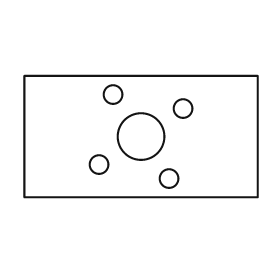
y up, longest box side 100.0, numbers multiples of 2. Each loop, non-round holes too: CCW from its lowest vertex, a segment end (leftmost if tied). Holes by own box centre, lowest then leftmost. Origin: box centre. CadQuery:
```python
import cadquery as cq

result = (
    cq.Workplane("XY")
    .moveTo(-50.0, -26.0)
    .lineTo(50.0, -26.0)
    .lineTo(50.0, 26.0)
    .lineTo(-50.0, 26.0)
    .close()
    .moveTo(12.0, -18.0)
    .circle(4.0)
    .moveTo(-18.0, -12.0)
    .circle(4.0)
    .moveTo(0.0, 0.0)
    .circle(10.0)
    .moveTo(18.0, 12.0)
    .circle(4.0)
    .moveTo(-12.0, 18.0)
    .circle(4.0)
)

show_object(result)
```